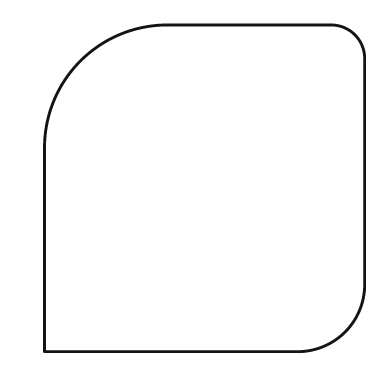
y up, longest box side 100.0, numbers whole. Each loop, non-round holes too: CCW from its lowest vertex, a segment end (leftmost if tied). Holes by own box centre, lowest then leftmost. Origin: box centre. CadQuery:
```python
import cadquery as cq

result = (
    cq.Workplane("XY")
    .moveTo(-49.0, -50.0)
    .lineTo(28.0, -50.0)
    .threePointArc((43.0, -44.0), (49.0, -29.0))
    .lineTo(49.0, 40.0)
    .threePointArc((46.0, 47.0), (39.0, 50.0))
    .lineTo(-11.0, 50.0)
    .threePointArc((-38.0, 39.0), (-49.0, 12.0))
    .close()
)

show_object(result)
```